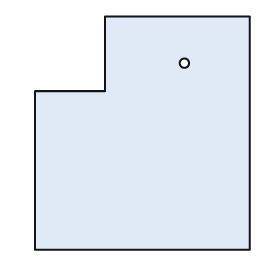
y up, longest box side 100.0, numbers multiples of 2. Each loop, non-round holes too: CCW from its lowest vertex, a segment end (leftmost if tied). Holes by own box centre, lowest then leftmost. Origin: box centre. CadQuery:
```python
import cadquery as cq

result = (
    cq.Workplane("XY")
    .moveTo(-46.0, -50.0)
    .lineTo(46.0, -50.0)
    .lineTo(46.0, 50.0)
    .lineTo(-16.0, 50.0)
    .lineTo(-16.0, 18.0)
    .lineTo(-46.0, 18.0)
    .close()
    .moveTo(18.0, 30.0)
    .circle(2.0)
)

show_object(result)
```